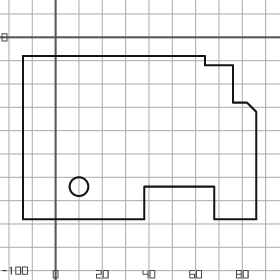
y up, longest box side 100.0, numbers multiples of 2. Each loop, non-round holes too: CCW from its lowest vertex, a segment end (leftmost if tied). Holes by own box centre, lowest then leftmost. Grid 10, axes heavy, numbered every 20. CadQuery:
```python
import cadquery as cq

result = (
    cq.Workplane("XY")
    .moveTo(-14.0, -78.0)
    .lineTo(38.0, -78.0)
    .lineTo(38.0, -64.0)
    .lineTo(68.0, -64.0)
    .lineTo(68.0, -78.0)
    .lineTo(86.0, -78.0)
    .lineTo(86.0, -32.0)
    .lineTo(82.0, -28.0)
    .lineTo(76.0, -28.0)
    .lineTo(76.0, -12.0)
    .lineTo(64.0, -12.0)
    .lineTo(64.0, -8.0)
    .lineTo(-14.0, -8.0)
    .close()
    .moveTo(10.0, -64.0)
    .circle(4.0)
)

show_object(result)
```